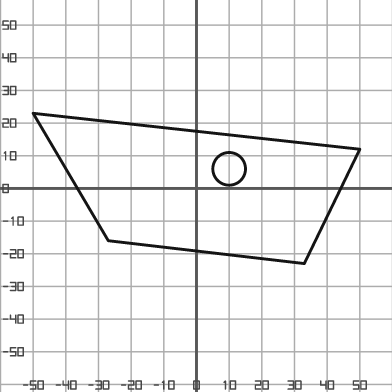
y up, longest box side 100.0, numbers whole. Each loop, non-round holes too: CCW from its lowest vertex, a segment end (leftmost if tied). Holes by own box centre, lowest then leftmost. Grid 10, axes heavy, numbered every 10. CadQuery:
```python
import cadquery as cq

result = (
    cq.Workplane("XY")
    .moveTo(33.0, -23.0)
    .lineTo(50.0, 12.0)
    .lineTo(-50.0, 23.0)
    .lineTo(-27.0, -16.0)
    .close()
    .moveTo(10.0, 6.0)
    .circle(5.0)
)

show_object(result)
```